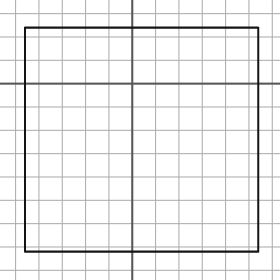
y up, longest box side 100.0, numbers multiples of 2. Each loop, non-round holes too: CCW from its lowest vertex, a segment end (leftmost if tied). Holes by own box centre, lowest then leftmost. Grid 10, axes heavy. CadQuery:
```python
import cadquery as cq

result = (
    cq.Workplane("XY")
    .moveTo(-46.0, -72.0)
    .lineTo(54.0, -72.0)
    .lineTo(54.0, 24.0)
    .lineTo(-46.0, 24.0)
    .close()
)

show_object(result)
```